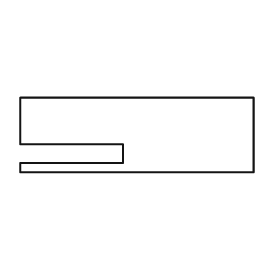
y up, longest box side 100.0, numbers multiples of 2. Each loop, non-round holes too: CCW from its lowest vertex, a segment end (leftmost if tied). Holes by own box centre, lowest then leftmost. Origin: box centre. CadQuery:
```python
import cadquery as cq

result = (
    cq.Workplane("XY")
    .moveTo(-50.0, -16.0)
    .lineTo(50.0, -16.0)
    .lineTo(50.0, 16.0)
    .lineTo(-50.0, 16.0)
    .lineTo(-50.0, -4.0)
    .lineTo(-6.0, -4.0)
    .lineTo(-6.0, -12.0)
    .lineTo(-50.0, -12.0)
    .close()
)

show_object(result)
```